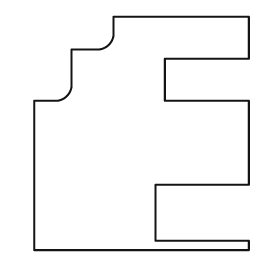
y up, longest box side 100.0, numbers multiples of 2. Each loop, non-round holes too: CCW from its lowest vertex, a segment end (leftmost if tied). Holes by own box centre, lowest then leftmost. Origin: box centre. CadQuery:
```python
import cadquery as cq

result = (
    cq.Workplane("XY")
    .moveTo(-46.0, -50.0)
    .lineTo(46.0, -50.0)
    .lineTo(46.0, -46.0)
    .lineTo(6.0, -46.0)
    .lineTo(6.0, -22.0)
    .lineTo(46.0, -22.0)
    .lineTo(46.0, 14.0)
    .lineTo(10.0, 14.0)
    .lineTo(10.0, 32.0)
    .lineTo(46.0, 32.0)
    .lineTo(46.0, 50.0)
    .lineTo(-12.0, 50.0)
    .lineTo(-12.0, 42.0)
    .threePointArc((-14.0, 38.0), (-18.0, 36.0))
    .lineTo(-30.0, 36.0)
    .lineTo(-30.0, 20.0)
    .threePointArc((-32.0, 16.0), (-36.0, 14.0))
    .lineTo(-46.0, 14.0)
    .close()
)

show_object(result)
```